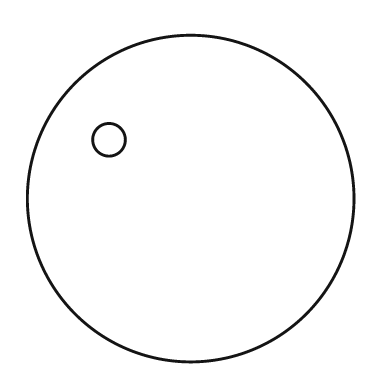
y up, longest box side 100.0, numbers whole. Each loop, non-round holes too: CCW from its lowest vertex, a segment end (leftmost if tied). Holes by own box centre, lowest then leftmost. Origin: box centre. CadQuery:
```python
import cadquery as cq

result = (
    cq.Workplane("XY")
    .moveTo(0.0, 0.0)
    .circle(50.0)
    .moveTo(-25.0, 18.0)
    .circle(5.0)
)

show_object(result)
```